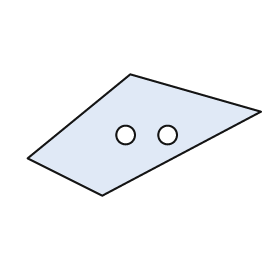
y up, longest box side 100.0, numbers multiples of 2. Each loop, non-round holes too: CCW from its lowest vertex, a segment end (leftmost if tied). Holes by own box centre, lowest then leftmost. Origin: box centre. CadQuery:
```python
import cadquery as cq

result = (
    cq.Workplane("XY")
    .moveTo(-18.0, -26.0)
    .lineTo(50.0, 10.0)
    .lineTo(-6.0, 26.0)
    .lineTo(-50.0, -10.0)
    .close()
    .moveTo(-8.0, 0.0)
    .circle(4.0)
    .moveTo(10.0, 0.0)
    .circle(4.0)
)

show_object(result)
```